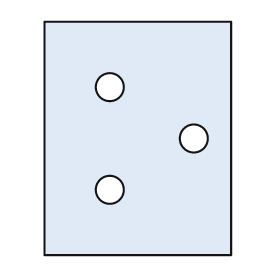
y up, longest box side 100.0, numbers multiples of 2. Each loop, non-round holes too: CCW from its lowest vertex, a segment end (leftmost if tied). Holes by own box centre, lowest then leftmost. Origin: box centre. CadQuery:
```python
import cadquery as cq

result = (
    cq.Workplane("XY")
    .moveTo(-40.0, -50.0)
    .lineTo(40.0, -50.0)
    .lineTo(40.0, 50.0)
    .lineTo(-40.0, 50.0)
    .close()
    .moveTo(-12.0, -22.0)
    .circle(6.0)
    .moveTo(24.0, 0.0)
    .circle(6.0)
    .moveTo(-12.0, 22.0)
    .circle(6.0)
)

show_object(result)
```